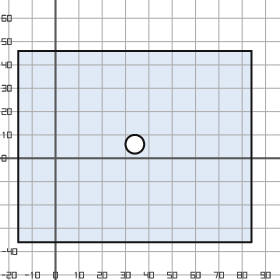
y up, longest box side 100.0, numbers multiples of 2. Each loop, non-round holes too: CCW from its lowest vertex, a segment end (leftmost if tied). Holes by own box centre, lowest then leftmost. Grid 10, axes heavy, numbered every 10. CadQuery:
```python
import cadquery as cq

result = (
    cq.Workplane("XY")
    .moveTo(-16.0, -36.0)
    .lineTo(84.0, -36.0)
    .lineTo(84.0, 46.0)
    .lineTo(-16.0, 46.0)
    .close()
    .moveTo(34.0, 6.0)
    .circle(4.0)
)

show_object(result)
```